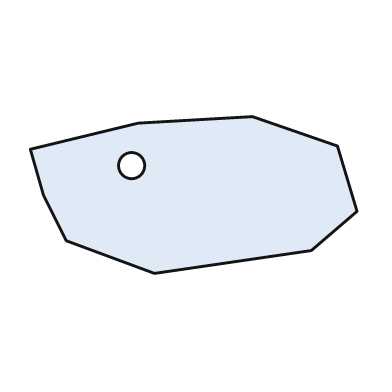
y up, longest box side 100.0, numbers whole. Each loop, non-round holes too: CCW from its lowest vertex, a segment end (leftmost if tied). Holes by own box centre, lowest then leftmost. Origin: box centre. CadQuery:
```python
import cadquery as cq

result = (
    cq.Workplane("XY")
    .moveTo(-12.0, -24.0)
    .lineTo(36.0, -17.0)
    .lineTo(50.0, -5.0)
    .lineTo(44.0, 15.0)
    .lineTo(18.0, 24.0)
    .lineTo(-17.0, 22.0)
    .lineTo(-50.0, 14.0)
    .lineTo(-46.0, 0.0)
    .lineTo(-39.0, -14.0)
    .close()
    .moveTo(-19.0, 9.0)
    .circle(4.0)
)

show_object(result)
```